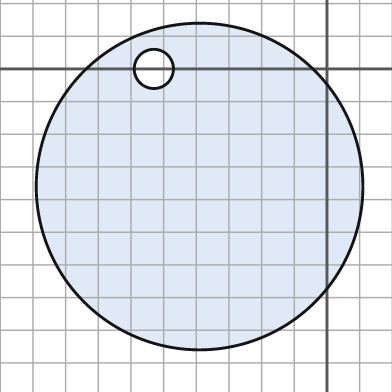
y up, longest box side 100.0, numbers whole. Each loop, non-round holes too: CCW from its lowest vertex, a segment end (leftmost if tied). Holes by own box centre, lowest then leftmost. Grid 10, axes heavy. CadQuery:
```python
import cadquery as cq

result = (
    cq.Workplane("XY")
    .moveTo(-39.0, -36.0)
    .circle(50.0)
    .moveTo(-53.0, 0.0)
    .circle(6.0)
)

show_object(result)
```